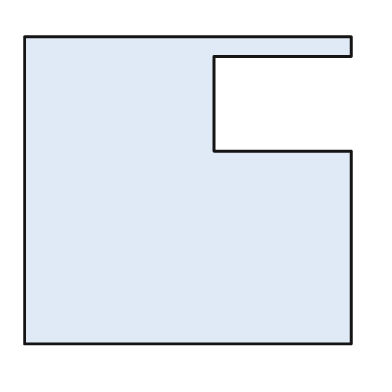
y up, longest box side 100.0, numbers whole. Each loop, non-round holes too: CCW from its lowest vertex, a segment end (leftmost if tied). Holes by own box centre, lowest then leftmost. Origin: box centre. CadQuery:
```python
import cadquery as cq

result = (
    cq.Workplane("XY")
    .moveTo(-50.0, -47.0)
    .lineTo(50.0, -47.0)
    .lineTo(50.0, 12.0)
    .lineTo(8.0, 12.0)
    .lineTo(8.0, 41.0)
    .lineTo(50.0, 41.0)
    .lineTo(50.0, 47.0)
    .lineTo(-50.0, 47.0)
    .close()
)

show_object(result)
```